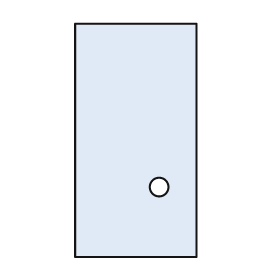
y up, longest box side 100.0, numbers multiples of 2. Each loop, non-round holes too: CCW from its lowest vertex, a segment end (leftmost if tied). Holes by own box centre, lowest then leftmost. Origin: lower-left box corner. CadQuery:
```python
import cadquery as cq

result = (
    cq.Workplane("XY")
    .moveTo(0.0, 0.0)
    .lineTo(52.0, 0.0)
    .lineTo(52.0, 100.0)
    .lineTo(0.0, 100.0)
    .close()
    .moveTo(36.0, 30.0)
    .circle(4.0)
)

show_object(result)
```